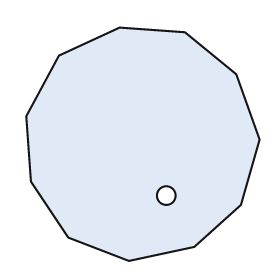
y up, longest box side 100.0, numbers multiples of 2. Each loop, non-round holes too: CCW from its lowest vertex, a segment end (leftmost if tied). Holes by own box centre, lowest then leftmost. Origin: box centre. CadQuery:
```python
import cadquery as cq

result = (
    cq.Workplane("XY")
    .moveTo(-6.0, -50.0)
    .lineTo(22.0, -44.0)
    .lineTo(42.0, -26.0)
    .lineTo(50.0, 2.0)
    .lineTo(40.0, 30.0)
    .lineTo(18.0, 48.0)
    .lineTo(-10.0, 50.0)
    .lineTo(-36.0, 38.0)
    .lineTo(-50.0, 12.0)
    .lineTo(-48.0, -16.0)
    .lineTo(-32.0, -40.0)
    .close()
    .moveTo(10.0, -22.0)
    .circle(4.0)
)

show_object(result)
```